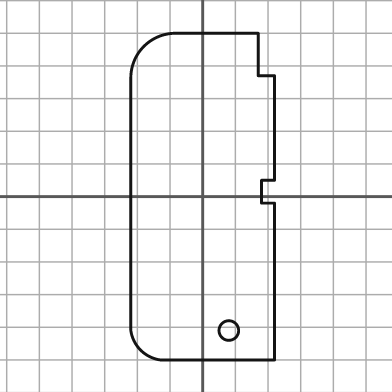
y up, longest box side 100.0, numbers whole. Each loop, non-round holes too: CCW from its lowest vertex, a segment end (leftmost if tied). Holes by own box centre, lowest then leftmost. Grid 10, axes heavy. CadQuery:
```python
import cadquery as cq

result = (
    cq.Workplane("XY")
    .moveTo(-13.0, -50.0)
    .lineTo(22.0, -50.0)
    .lineTo(22.0, -2.0)
    .lineTo(18.0, -2.0)
    .lineTo(18.0, 5.0)
    .lineTo(22.0, 5.0)
    .lineTo(22.0, 37.0)
    .lineTo(17.0, 37.0)
    .lineTo(17.0, 50.0)
    .lineTo(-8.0, 50.0)
    .threePointArc((-18.0, 46.0), (-22.0, 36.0))
    .lineTo(-22.0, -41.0)
    .threePointArc((-19.0, -47.0), (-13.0, -50.0))
    .close()
    .moveTo(8.0, -41.0)
    .circle(3.0)
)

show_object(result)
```